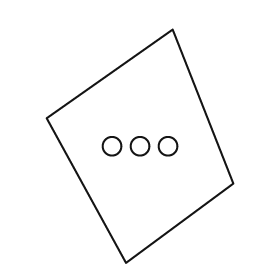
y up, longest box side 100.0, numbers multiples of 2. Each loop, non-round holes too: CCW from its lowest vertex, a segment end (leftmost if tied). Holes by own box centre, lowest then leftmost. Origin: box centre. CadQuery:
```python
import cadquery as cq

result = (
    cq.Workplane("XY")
    .moveTo(-6.0, -50.0)
    .lineTo(40.0, -16.0)
    .lineTo(14.0, 50.0)
    .lineTo(-40.0, 12.0)
    .close()
    .moveTo(-12.0, 0.0)
    .circle(4.0)
    .moveTo(0.0, 0.0)
    .circle(4.0)
    .moveTo(12.0, 0.0)
    .circle(4.0)
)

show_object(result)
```